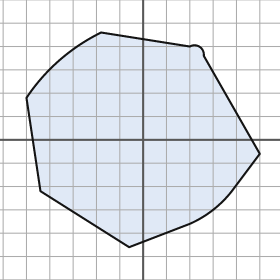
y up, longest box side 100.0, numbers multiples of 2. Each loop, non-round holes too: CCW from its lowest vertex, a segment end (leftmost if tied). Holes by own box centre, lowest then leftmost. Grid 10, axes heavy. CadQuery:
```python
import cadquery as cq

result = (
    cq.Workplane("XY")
    .moveTo(-6.0, -46.0)
    .lineTo(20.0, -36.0)
    .threePointArc((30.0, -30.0), (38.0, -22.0))
    .lineTo(50.0, -6.0)
    .lineTo(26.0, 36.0)
    .threePointArc((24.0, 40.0), (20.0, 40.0))
    .lineTo(-18.0, 46.0)
    .threePointArc((-36.0, 34.0), (-50.0, 18.0))
    .lineTo(-44.0, -22.0)
    .close()
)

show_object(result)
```